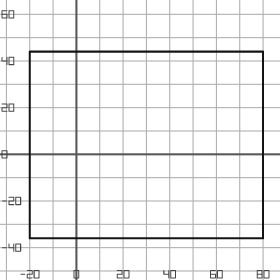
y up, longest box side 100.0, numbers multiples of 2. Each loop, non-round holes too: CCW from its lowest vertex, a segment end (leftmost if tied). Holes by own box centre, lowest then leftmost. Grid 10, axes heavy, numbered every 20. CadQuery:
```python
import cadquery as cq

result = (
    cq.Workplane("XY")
    .moveTo(-20.0, -36.0)
    .lineTo(80.0, -36.0)
    .lineTo(80.0, 44.0)
    .lineTo(-20.0, 44.0)
    .close()
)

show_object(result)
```